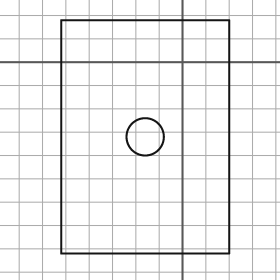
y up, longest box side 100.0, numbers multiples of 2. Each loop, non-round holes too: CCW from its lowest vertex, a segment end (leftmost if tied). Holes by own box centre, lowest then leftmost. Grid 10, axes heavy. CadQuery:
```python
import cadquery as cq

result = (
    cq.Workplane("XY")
    .moveTo(-52.0, -82.0)
    .lineTo(20.0, -82.0)
    .lineTo(20.0, 18.0)
    .lineTo(-52.0, 18.0)
    .close()
    .moveTo(-16.0, -32.0)
    .circle(8.0)
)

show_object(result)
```